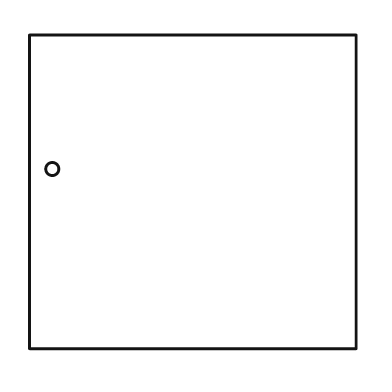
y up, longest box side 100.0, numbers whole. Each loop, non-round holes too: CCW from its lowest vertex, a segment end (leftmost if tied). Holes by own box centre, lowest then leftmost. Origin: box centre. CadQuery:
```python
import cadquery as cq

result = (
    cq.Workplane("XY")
    .moveTo(-50.0, -48.0)
    .lineTo(50.0, -48.0)
    .lineTo(50.0, 48.0)
    .lineTo(-50.0, 48.0)
    .close()
    .moveTo(-43.0, 7.0)
    .circle(2.0)
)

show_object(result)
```